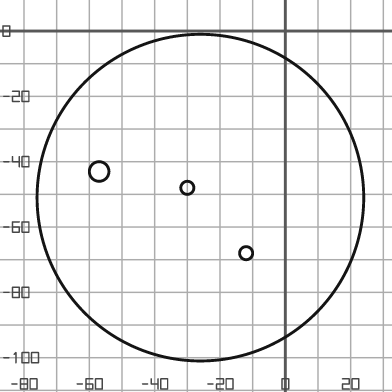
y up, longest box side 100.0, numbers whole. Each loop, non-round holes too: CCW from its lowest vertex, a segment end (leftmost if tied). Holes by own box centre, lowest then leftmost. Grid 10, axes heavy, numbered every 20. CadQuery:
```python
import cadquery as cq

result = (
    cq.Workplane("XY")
    .moveTo(-26.0, -51.0)
    .circle(50.0)
    .moveTo(-12.0, -68.0)
    .circle(2.0)
    .moveTo(-30.0, -48.0)
    .circle(2.0)
    .moveTo(-57.0, -43.0)
    .circle(3.0)
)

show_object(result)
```